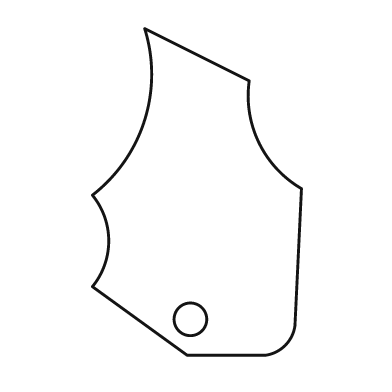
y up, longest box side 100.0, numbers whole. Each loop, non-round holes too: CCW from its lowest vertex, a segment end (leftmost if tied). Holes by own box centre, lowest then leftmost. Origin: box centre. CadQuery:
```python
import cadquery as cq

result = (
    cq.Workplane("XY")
    .moveTo(-3.0, -50.0)
    .lineTo(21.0, -50.0)
    .threePointArc((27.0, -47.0), (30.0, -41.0))
    .lineTo(32.0, 1.0)
    .threePointArc((19.0, 15.0), (16.0, 34.0))
    .lineTo(-16.0, 50.0)
    .threePointArc((-16.0, 22.0), (-32.0, -1.0))
    .threePointArc((-27.0, -15.0), (-32.0, -29.0))
    .close()
    .moveTo(-2.0, -39.0)
    .circle(5.0)
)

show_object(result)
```